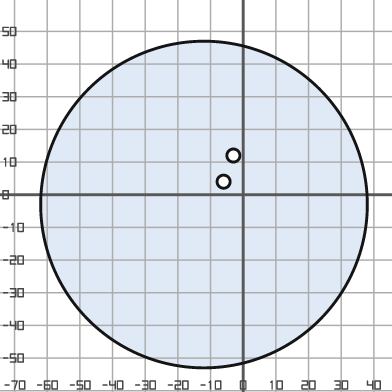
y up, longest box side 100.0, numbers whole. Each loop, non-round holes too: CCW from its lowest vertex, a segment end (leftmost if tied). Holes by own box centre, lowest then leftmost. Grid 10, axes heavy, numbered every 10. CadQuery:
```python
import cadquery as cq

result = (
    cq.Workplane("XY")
    .moveTo(-12.0, -3.0)
    .circle(50.0)
    .moveTo(-6.0, 4.0)
    .circle(2.0)
    .moveTo(-3.0, 12.0)
    .circle(2.0)
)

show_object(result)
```